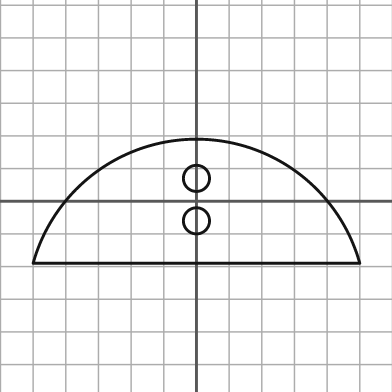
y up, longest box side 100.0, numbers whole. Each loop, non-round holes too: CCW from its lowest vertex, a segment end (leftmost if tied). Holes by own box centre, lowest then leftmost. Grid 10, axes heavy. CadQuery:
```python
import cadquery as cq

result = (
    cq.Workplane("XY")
    .moveTo(-50.0, -19.0)
    .lineTo(50.0, -19.0)
    .threePointArc((0.0, 19.0), (-50.0, -19.0))
    .close()
    .moveTo(0.0, -6.0)
    .circle(4.0)
    .moveTo(0.0, 7.0)
    .circle(4.0)
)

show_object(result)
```